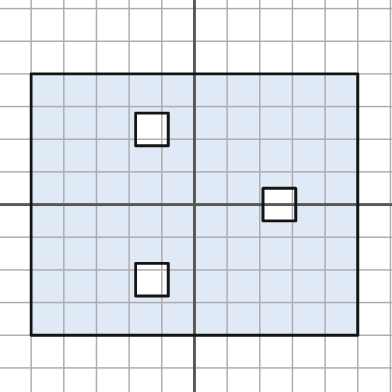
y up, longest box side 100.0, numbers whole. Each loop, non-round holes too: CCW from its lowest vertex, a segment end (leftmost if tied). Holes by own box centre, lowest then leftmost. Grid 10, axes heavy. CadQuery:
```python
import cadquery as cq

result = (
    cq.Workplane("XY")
    .moveTo(-50.0, -40.0)
    .lineTo(50.0, -40.0)
    .lineTo(50.0, 40.0)
    .lineTo(-50.0, 40.0)
    .close()
    .moveTo(-18.0, -28.0)
    .lineTo(-8.0, -28.0)
    .lineTo(-8.0, -18.0)
    .lineTo(-18.0, -18.0)
    .close()
    .moveTo(21.0, -5.0)
    .lineTo(31.0, -5.0)
    .lineTo(31.0, 5.0)
    .lineTo(21.0, 5.0)
    .close()
    .moveTo(-18.0, 18.0)
    .lineTo(-8.0, 18.0)
    .lineTo(-8.0, 28.0)
    .lineTo(-18.0, 28.0)
    .close()
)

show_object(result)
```